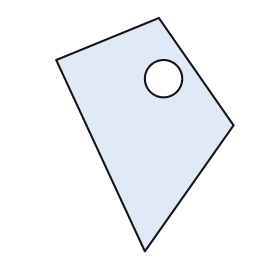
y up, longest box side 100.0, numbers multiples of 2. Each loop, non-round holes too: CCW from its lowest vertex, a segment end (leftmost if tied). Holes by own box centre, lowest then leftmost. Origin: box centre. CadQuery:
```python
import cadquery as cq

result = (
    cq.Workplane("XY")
    .moveTo(0.0, -50.0)
    .lineTo(38.0, 4.0)
    .lineTo(6.0, 50.0)
    .lineTo(-38.0, 32.0)
    .close()
    .moveTo(8.0, 24.0)
    .circle(8.0)
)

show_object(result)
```